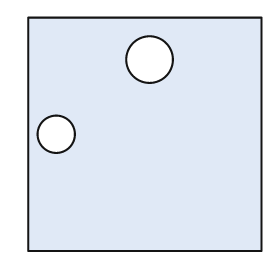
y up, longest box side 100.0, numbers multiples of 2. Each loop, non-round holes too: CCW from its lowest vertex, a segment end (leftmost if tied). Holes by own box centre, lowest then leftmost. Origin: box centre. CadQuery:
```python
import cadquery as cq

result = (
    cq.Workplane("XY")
    .moveTo(-50.0, -50.0)
    .lineTo(50.0, -50.0)
    .lineTo(50.0, 50.0)
    .lineTo(-50.0, 50.0)
    .close()
    .moveTo(-38.0, 0.0)
    .circle(8.0)
    .moveTo(2.0, 32.0)
    .circle(10.0)
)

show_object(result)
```